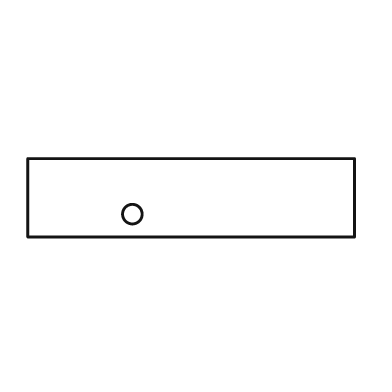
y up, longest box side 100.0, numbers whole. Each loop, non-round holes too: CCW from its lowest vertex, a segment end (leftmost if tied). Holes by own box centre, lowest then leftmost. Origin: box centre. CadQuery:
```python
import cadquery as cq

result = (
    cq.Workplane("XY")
    .moveTo(-50.0, -12.0)
    .lineTo(50.0, -12.0)
    .lineTo(50.0, 12.0)
    .lineTo(-50.0, 12.0)
    .close()
    .moveTo(-18.0, -5.0)
    .circle(3.0)
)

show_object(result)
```